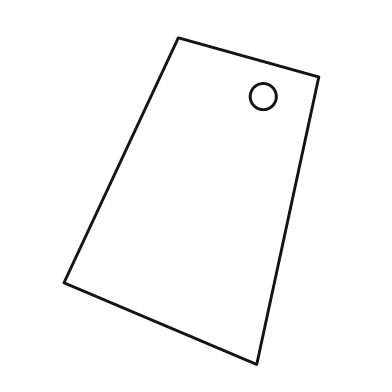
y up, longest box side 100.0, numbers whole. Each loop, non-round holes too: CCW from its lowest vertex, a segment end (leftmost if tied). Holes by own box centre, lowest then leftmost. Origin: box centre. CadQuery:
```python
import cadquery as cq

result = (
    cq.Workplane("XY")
    .moveTo(20.0, -50.0)
    .lineTo(39.0, 38.0)
    .lineTo(-4.0, 50.0)
    .lineTo(-39.0, -25.0)
    .close()
    .moveTo(22.0, 32.0)
    .circle(4.0)
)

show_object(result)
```